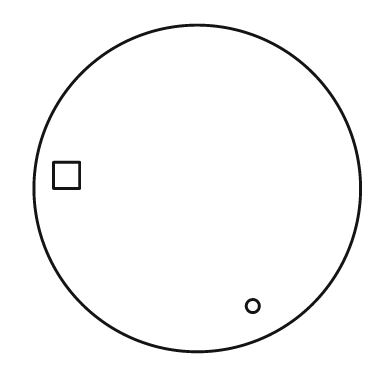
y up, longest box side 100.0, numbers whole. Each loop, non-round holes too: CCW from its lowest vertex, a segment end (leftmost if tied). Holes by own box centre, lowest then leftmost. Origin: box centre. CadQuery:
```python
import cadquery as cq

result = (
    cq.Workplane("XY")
    .moveTo(0.0, 0.0)
    .circle(50.0)
    .moveTo(17.0, -36.0)
    .circle(2.0)
    .moveTo(-44.0, 0.0)
    .lineTo(-36.0, 0.0)
    .lineTo(-36.0, 8.0)
    .lineTo(-44.0, 8.0)
    .close()
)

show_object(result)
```